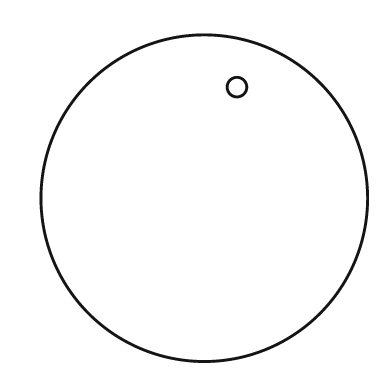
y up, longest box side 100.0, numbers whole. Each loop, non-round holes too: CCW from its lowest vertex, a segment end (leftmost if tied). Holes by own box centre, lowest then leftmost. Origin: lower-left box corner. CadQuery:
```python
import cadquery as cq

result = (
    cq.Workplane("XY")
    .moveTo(50.0, 50.0)
    .circle(50.0)
    .moveTo(60.0, 84.0)
    .circle(3.0)
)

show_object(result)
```